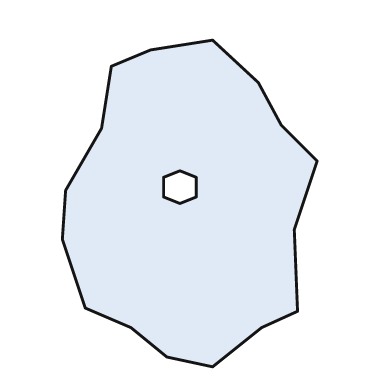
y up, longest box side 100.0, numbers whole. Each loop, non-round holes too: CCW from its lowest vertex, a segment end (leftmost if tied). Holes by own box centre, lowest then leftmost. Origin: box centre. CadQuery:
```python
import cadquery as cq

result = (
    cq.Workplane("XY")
    .moveTo(7.0, -50.0)
    .lineTo(22.0, -38.0)
    .lineTo(33.0, -33.0)
    .lineTo(32.0, -8.0)
    .lineTo(39.0, 13.0)
    .lineTo(28.0, 24.0)
    .lineTo(21.0, 37.0)
    .lineTo(7.0, 50.0)
    .lineTo(-12.0, 47.0)
    .lineTo(-24.0, 42.0)
    .lineTo(-27.0, 23.0)
    .lineTo(-38.0, 4.0)
    .lineTo(-39.0, -11.0)
    .lineTo(-32.0, -32.0)
    .lineTo(-18.0, -38.0)
    .lineTo(-7.0, -47.0)
    .close()
    .moveTo(-3.0, 0.0)
    .lineTo(2.0, 2.0)
    .lineTo(2.0, 8.0)
    .lineTo(-3.0, 10.0)
    .lineTo(-8.0, 8.0)
    .lineTo(-8.0, 2.0)
    .close()
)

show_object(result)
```